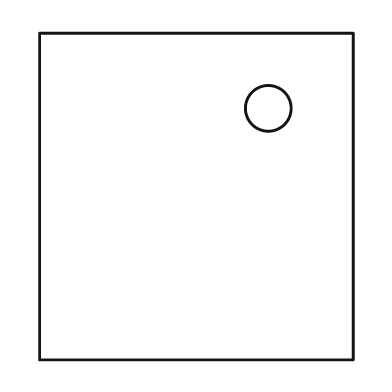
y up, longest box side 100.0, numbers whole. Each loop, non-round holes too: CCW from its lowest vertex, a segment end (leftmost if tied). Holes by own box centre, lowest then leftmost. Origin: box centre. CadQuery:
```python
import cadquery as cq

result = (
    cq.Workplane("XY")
    .moveTo(-48.0, -50.0)
    .lineTo(48.0, -50.0)
    .lineTo(48.0, 50.0)
    .lineTo(-48.0, 50.0)
    .close()
    .moveTo(22.0, 27.0)
    .circle(7.0)
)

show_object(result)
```